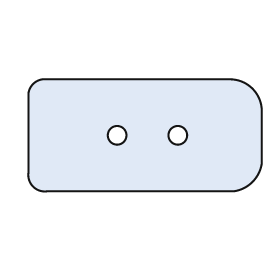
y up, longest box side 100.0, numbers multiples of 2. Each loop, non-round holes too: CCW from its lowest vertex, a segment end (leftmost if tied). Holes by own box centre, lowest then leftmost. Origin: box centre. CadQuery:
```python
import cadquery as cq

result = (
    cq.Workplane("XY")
    .moveTo(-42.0, -24.0)
    .lineTo(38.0, -24.0)
    .threePointArc((46.0, -20.0), (50.0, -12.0))
    .lineTo(50.0, 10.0)
    .threePointArc((46.0, 20.0), (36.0, 24.0))
    .lineTo(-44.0, 24.0)
    .threePointArc((-48.0, 22.0), (-50.0, 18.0))
    .lineTo(-50.0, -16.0)
    .threePointArc((-48.0, -22.0), (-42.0, -24.0))
    .close()
    .moveTo(-12.0, 0.0)
    .circle(4.0)
    .moveTo(14.0, 0.0)
    .circle(4.0)
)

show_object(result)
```